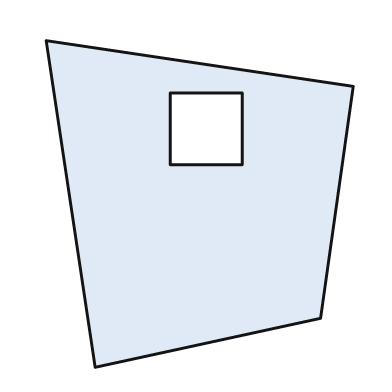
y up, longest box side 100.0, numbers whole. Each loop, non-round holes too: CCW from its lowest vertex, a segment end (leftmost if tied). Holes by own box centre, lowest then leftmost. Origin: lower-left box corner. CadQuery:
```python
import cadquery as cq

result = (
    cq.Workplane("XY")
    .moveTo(15.0, 0.0)
    .lineTo(84.0, 15.0)
    .lineTo(94.0, 86.0)
    .lineTo(0.0, 100.0)
    .close()
    .moveTo(38.0, 62.0)
    .lineTo(60.0, 62.0)
    .lineTo(60.0, 84.0)
    .lineTo(38.0, 84.0)
    .close()
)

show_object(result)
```